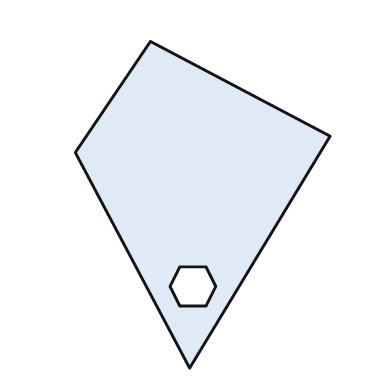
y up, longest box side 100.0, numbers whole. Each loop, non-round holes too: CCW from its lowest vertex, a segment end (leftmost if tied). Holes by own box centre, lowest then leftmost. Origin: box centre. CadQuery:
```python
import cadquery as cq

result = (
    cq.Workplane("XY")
    .moveTo(-4.0, -50.0)
    .lineTo(39.0, 21.0)
    .lineTo(-16.0, 50.0)
    .lineTo(-39.0, 16.0)
    .close()
    .moveTo(-7.0, -31.0)
    .lineTo(1.0, -31.0)
    .lineTo(4.0, -25.0)
    .lineTo(1.0, -19.0)
    .lineTo(-7.0, -19.0)
    .lineTo(-10.0, -25.0)
    .close()
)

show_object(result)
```